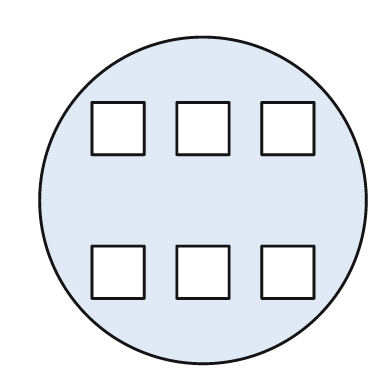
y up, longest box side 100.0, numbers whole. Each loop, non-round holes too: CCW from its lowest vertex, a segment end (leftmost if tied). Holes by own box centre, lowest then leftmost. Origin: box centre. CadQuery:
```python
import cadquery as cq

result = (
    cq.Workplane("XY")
    .moveTo(0.0, 0.0)
    .circle(50.0)
    .moveTo(-34.0, -30.0)
    .lineTo(-18.0, -30.0)
    .lineTo(-18.0, -14.0)
    .lineTo(-34.0, -14.0)
    .close()
    .moveTo(-8.0, -30.0)
    .lineTo(8.0, -30.0)
    .lineTo(8.0, -14.0)
    .lineTo(-8.0, -14.0)
    .close()
    .moveTo(18.0, -30.0)
    .lineTo(34.0, -30.0)
    .lineTo(34.0, -14.0)
    .lineTo(18.0, -14.0)
    .close()
    .moveTo(-34.0, 14.0)
    .lineTo(-18.0, 14.0)
    .lineTo(-18.0, 30.0)
    .lineTo(-34.0, 30.0)
    .close()
    .moveTo(-8.0, 14.0)
    .lineTo(8.0, 14.0)
    .lineTo(8.0, 30.0)
    .lineTo(-8.0, 30.0)
    .close()
    .moveTo(18.0, 14.0)
    .lineTo(34.0, 14.0)
    .lineTo(34.0, 30.0)
    .lineTo(18.0, 30.0)
    .close()
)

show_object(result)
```